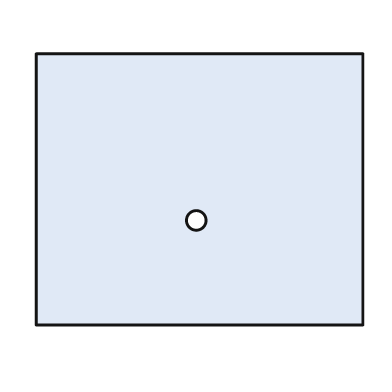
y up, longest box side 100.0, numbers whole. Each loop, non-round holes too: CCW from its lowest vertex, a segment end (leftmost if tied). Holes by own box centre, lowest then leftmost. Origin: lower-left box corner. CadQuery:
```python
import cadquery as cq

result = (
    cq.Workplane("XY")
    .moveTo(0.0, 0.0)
    .lineTo(100.0, 0.0)
    .lineTo(100.0, 83.0)
    .lineTo(0.0, 83.0)
    .close()
    .moveTo(49.0, 32.0)
    .circle(3.0)
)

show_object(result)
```